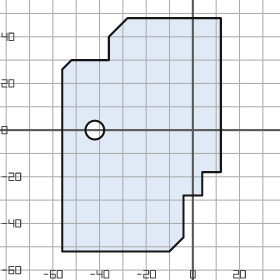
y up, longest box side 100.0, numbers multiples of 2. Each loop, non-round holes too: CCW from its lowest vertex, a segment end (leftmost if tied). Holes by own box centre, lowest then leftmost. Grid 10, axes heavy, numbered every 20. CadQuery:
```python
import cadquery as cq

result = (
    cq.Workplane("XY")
    .moveTo(-56.0, -52.0)
    .lineTo(-10.0, -52.0)
    .lineTo(-4.0, -46.0)
    .lineTo(-4.0, -28.0)
    .lineTo(4.0, -28.0)
    .lineTo(4.0, -18.0)
    .lineTo(12.0, -18.0)
    .lineTo(12.0, 48.0)
    .lineTo(-28.0, 48.0)
    .lineTo(-36.0, 40.0)
    .lineTo(-36.0, 30.0)
    .lineTo(-52.0, 30.0)
    .lineTo(-56.0, 26.0)
    .close()
    .moveTo(-42.0, 0.0)
    .circle(4.0)
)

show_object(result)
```